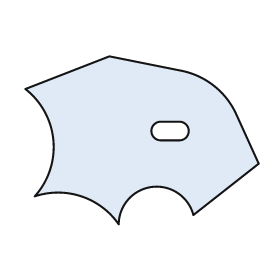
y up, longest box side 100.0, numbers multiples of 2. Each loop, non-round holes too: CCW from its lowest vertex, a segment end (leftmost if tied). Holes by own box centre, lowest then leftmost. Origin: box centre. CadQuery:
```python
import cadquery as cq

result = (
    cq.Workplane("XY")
    .moveTo(-10.0, -36.0)
    .threePointArc((4.0, -20.0), (22.0, -32.0))
    .lineTo(50.0, -10.0)
    .lineTo(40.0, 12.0)
    .threePointArc((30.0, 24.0), (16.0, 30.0))
    .lineTo(-14.0, 36.0)
    .lineTo(-50.0, 22.0)
    .threePointArc((-38.0, 0.0), (-46.0, -24.0))
    .threePointArc((-26.0, -24.0), (-10.0, -36.0))
    .close()
    .moveTo(8.0, 0.0)
    .lineTo(16.0, 0.0)
    .threePointArc((20.0, 4.0), (16.0, 8.0))
    .lineTo(8.0, 8.0)
    .threePointArc((4.0, 4.0), (8.0, 0.0))
    .close()
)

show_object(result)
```